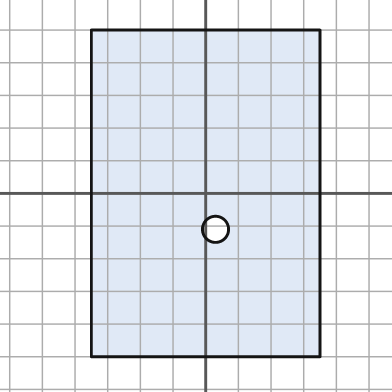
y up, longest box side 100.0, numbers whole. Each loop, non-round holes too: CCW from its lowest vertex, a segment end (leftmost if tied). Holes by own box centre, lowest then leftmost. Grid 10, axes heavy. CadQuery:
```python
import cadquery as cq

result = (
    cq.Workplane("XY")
    .moveTo(-35.0, -50.0)
    .lineTo(35.0, -50.0)
    .lineTo(35.0, 50.0)
    .lineTo(-35.0, 50.0)
    .close()
    .moveTo(3.0, -11.0)
    .circle(4.0)
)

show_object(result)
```